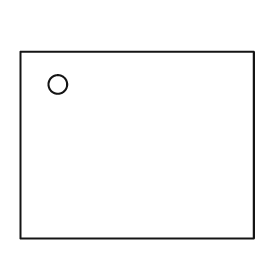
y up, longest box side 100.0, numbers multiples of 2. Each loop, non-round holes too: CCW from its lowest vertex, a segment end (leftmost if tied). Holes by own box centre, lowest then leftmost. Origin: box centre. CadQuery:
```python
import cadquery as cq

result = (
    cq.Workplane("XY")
    .moveTo(-50.0, -40.0)
    .lineTo(50.0, -40.0)
    .lineTo(50.0, 40.0)
    .lineTo(-50.0, 40.0)
    .close()
    .moveTo(-34.0, 26.0)
    .circle(4.0)
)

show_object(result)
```